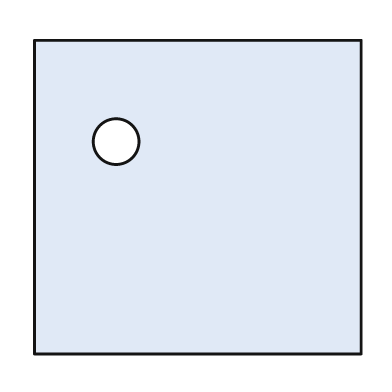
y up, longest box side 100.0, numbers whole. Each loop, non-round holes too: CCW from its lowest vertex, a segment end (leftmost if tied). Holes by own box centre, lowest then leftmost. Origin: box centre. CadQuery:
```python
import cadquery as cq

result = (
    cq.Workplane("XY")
    .moveTo(-50.0, -48.0)
    .lineTo(50.0, -48.0)
    .lineTo(50.0, 48.0)
    .lineTo(-50.0, 48.0)
    .close()
    .moveTo(-25.0, 17.0)
    .circle(7.0)
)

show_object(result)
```